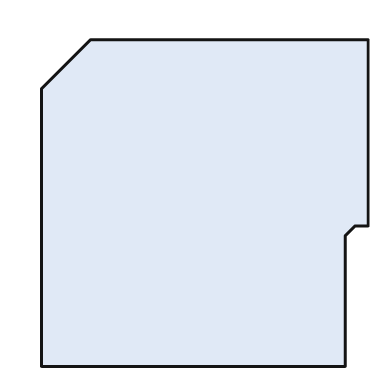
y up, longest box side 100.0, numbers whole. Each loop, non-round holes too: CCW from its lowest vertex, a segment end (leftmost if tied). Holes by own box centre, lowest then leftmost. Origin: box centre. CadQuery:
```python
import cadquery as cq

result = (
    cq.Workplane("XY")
    .moveTo(-50.0, -50.0)
    .lineTo(43.0, -50.0)
    .lineTo(43.0, -10.0)
    .lineTo(46.0, -7.0)
    .lineTo(50.0, -7.0)
    .lineTo(50.0, 50.0)
    .lineTo(-35.0, 50.0)
    .lineTo(-50.0, 35.0)
    .close()
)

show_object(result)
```